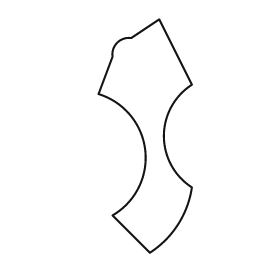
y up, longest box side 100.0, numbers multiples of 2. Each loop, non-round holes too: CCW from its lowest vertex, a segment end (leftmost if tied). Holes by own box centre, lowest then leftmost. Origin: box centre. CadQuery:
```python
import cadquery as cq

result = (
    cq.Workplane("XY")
    .moveTo(2.0, -50.0)
    .threePointArc((14.0, -38.0), (20.0, -22.0))
    .threePointArc((8.0, 0.0), (20.0, 22.0))
    .lineTo(6.0, 50.0)
    .lineTo(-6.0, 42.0)
    .threePointArc((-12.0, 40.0), (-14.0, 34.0))
    .lineTo(-20.0, 18.0)
    .threePointArc((0.0, -6.0), (-14.0, -34.0))
    .close()
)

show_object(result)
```